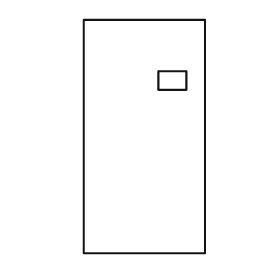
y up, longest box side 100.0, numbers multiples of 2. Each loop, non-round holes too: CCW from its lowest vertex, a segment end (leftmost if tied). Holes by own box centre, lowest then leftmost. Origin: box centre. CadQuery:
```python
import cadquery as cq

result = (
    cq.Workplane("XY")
    .moveTo(-26.0, -50.0)
    .lineTo(26.0, -50.0)
    .lineTo(26.0, 50.0)
    .lineTo(-26.0, 50.0)
    .close()
    .moveTo(6.0, 20.0)
    .lineTo(18.0, 20.0)
    .lineTo(18.0, 28.0)
    .lineTo(6.0, 28.0)
    .close()
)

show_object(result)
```